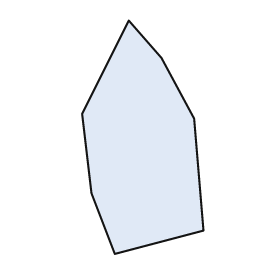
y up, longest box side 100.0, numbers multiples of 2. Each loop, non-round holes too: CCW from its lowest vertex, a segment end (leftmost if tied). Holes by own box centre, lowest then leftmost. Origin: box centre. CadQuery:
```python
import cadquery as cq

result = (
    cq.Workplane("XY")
    .moveTo(-12.0, -50.0)
    .lineTo(26.0, -40.0)
    .lineTo(22.0, 8.0)
    .lineTo(8.0, 34.0)
    .lineTo(-6.0, 50.0)
    .lineTo(-26.0, 10.0)
    .lineTo(-22.0, -24.0)
    .close()
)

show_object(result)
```